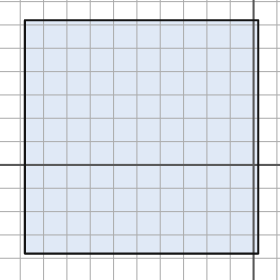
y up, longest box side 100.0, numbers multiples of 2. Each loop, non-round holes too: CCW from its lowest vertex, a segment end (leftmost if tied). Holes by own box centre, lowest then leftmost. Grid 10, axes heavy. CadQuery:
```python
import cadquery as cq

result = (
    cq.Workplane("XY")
    .moveTo(-98.0, -38.0)
    .lineTo(2.0, -38.0)
    .lineTo(2.0, 62.0)
    .lineTo(-98.0, 62.0)
    .close()
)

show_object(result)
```